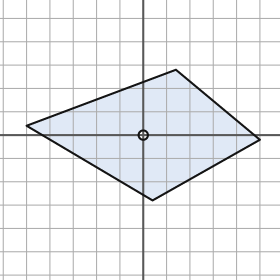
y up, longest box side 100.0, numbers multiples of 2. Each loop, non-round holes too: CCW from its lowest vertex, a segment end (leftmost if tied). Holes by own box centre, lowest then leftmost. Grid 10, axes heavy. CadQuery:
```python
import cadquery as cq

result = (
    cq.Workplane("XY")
    .moveTo(4.0, -28.0)
    .lineTo(50.0, -2.0)
    .lineTo(14.0, 28.0)
    .lineTo(-50.0, 4.0)
    .close()
    .moveTo(0.0, 0.0)
    .circle(2.0)
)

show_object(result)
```